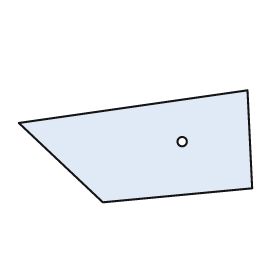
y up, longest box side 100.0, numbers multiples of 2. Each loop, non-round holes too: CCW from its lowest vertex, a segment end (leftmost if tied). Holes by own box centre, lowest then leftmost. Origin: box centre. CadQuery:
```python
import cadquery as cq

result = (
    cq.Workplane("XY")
    .moveTo(-14.0, -24.0)
    .lineTo(50.0, -18.0)
    .lineTo(48.0, 24.0)
    .lineTo(-50.0, 10.0)
    .close()
    .moveTo(20.0, 2.0)
    .circle(2.0)
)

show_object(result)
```